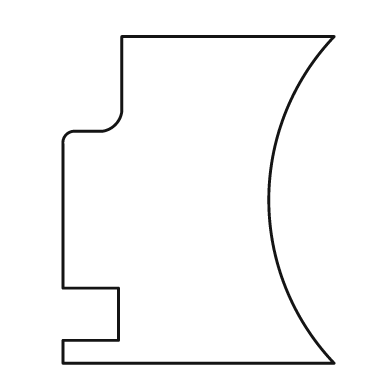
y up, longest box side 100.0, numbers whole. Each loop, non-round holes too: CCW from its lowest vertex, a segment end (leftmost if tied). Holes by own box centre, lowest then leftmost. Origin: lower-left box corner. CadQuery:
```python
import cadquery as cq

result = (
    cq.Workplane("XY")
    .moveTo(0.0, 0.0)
    .lineTo(83.0, 0.0)
    .threePointArc((63.0, 50.0), (83.0, 100.0))
    .lineTo(18.0, 100.0)
    .lineTo(18.0, 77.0)
    .threePointArc((16.0, 73.0), (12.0, 71.0))
    .lineTo(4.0, 71.0)
    .threePointArc((1.0, 70.0), (0.0, 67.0))
    .lineTo(0.0, 23.0)
    .lineTo(17.0, 23.0)
    .lineTo(17.0, 7.0)
    .lineTo(0.0, 7.0)
    .close()
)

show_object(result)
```